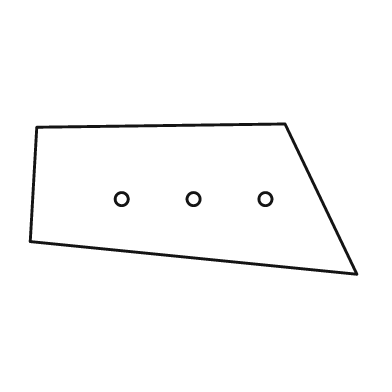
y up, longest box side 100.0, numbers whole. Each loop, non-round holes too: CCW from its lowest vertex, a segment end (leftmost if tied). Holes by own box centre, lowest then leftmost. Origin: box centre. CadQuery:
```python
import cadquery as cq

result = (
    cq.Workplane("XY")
    .moveTo(50.0, -23.0)
    .lineTo(28.0, 23.0)
    .lineTo(-48.0, 22.0)
    .lineTo(-50.0, -13.0)
    .close()
    .moveTo(-22.0, 0.0)
    .circle(2.0)
    .moveTo(0.0, 0.0)
    .circle(2.0)
    .moveTo(22.0, 0.0)
    .circle(2.0)
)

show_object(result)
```